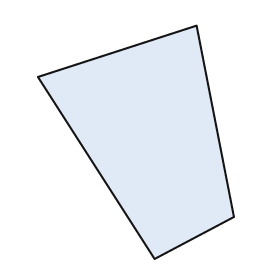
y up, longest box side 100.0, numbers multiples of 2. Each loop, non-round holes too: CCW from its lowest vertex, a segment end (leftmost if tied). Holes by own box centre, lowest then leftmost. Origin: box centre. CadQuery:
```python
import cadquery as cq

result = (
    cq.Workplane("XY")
    .moveTo(8.0, -50.0)
    .lineTo(42.0, -32.0)
    .lineTo(26.0, 50.0)
    .lineTo(-42.0, 28.0)
    .close()
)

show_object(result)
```